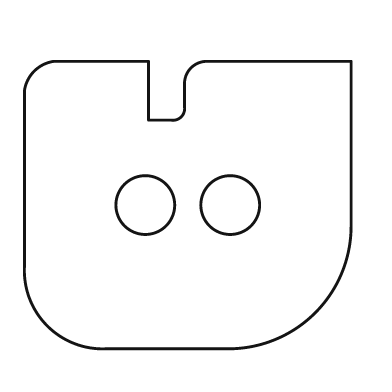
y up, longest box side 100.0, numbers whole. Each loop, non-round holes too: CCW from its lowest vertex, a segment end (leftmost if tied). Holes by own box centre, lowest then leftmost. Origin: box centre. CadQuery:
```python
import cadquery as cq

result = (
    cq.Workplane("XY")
    .moveTo(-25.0, -44.0)
    .lineTo(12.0, -44.0)
    .threePointArc((39.0, -33.0), (50.0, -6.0))
    .lineTo(50.0, 44.0)
    .lineTo(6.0, 44.0)
    .threePointArc((1.0, 42.0), (-1.0, 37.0))
    .lineTo(-1.0, 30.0)
    .threePointArc((-2.0, 27.0), (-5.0, 26.0))
    .lineTo(-12.0, 26.0)
    .lineTo(-12.0, 44.0)
    .lineTo(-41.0, 44.0)
    .threePointArc((-47.0, 41.0), (-50.0, 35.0))
    .lineTo(-50.0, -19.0)
    .threePointArc((-43.0, -37.0), (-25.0, -44.0))
    .close()
    .moveTo(-13.0, 0.0)
    .circle(9.0)
    .moveTo(13.0, 0.0)
    .circle(9.0)
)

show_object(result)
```